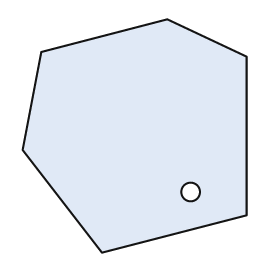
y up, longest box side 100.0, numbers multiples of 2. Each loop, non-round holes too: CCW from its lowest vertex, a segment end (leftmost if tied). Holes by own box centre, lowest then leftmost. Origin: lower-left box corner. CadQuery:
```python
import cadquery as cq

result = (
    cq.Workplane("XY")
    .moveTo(34.0, 0.0)
    .lineTo(96.0, 16.0)
    .lineTo(96.0, 84.0)
    .lineTo(62.0, 100.0)
    .lineTo(8.0, 86.0)
    .lineTo(0.0, 44.0)
    .close()
    .moveTo(72.0, 26.0)
    .circle(4.0)
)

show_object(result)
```